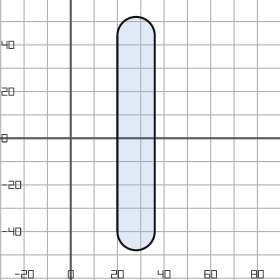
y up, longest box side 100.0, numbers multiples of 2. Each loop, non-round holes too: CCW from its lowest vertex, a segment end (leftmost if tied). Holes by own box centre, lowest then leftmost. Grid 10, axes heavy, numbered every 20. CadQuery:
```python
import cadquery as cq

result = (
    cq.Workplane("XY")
    .moveTo(20.0, -40.0)
    .threePointArc((28.0, -48.0), (36.0, -40.0))
    .lineTo(36.0, 44.0)
    .threePointArc((28.0, 52.0), (20.0, 44.0))
    .close()
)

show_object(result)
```